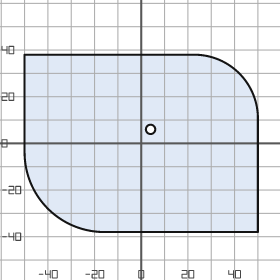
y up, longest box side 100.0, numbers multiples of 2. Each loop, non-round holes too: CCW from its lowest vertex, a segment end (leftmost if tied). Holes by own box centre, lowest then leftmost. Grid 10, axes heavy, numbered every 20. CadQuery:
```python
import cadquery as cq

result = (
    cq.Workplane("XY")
    .moveTo(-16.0, -38.0)
    .lineTo(50.0, -38.0)
    .lineTo(50.0, 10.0)
    .threePointArc((42.0, 30.0), (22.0, 38.0))
    .lineTo(-50.0, 38.0)
    .lineTo(-50.0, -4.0)
    .threePointArc((-40.0, -28.0), (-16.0, -38.0))
    .close()
    .moveTo(4.0, 6.0)
    .circle(2.0)
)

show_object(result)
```